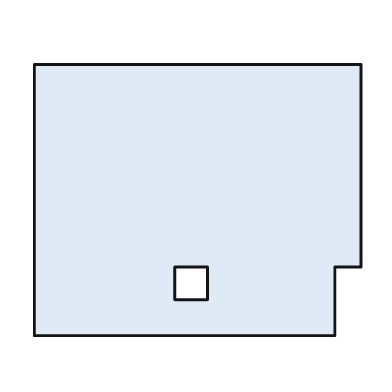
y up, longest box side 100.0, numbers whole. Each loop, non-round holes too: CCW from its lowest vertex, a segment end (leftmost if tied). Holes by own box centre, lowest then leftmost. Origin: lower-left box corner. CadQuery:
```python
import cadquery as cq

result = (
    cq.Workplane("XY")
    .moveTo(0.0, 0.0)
    .lineTo(92.0, 0.0)
    .lineTo(92.0, 21.0)
    .lineTo(100.0, 21.0)
    .lineTo(100.0, 83.0)
    .lineTo(0.0, 83.0)
    .close()
    .moveTo(43.0, 11.0)
    .lineTo(53.0, 11.0)
    .lineTo(53.0, 21.0)
    .lineTo(43.0, 21.0)
    .close()
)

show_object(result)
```